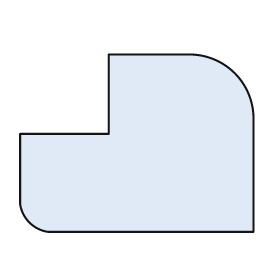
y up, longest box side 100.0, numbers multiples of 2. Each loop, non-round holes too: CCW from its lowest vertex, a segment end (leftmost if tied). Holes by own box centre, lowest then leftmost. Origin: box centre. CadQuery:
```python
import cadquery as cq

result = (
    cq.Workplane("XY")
    .moveTo(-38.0, -38.0)
    .lineTo(50.0, -38.0)
    .lineTo(50.0, 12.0)
    .threePointArc((42.0, 30.0), (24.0, 38.0))
    .lineTo(-12.0, 38.0)
    .lineTo(-12.0, 4.0)
    .lineTo(-50.0, 4.0)
    .lineTo(-50.0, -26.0)
    .threePointArc((-46.0, -34.0), (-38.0, -38.0))
    .close()
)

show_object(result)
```